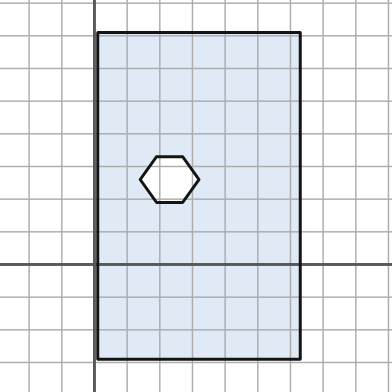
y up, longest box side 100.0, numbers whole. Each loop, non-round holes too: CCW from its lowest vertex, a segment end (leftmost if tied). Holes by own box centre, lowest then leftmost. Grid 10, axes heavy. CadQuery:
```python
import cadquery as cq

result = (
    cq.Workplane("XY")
    .moveTo(1.0, -29.0)
    .lineTo(63.0, -29.0)
    .lineTo(63.0, 71.0)
    .lineTo(1.0, 71.0)
    .close()
    .moveTo(19.0, 19.0)
    .lineTo(27.0, 19.0)
    .lineTo(32.0, 26.0)
    .lineTo(27.0, 33.0)
    .lineTo(19.0, 33.0)
    .lineTo(14.0, 26.0)
    .close()
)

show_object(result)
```